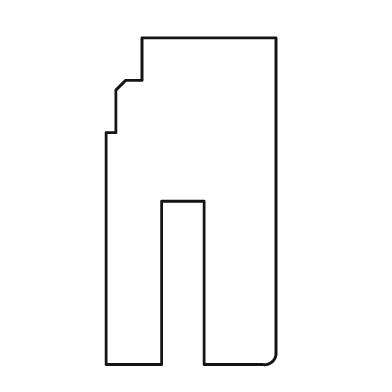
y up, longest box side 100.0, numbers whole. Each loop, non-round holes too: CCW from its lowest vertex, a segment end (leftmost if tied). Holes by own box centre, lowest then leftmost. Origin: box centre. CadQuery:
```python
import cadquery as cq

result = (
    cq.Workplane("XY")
    .moveTo(-26.0, -50.0)
    .lineTo(-9.0, -50.0)
    .lineTo(-9.0, 0.0)
    .lineTo(4.0, 0.0)
    .lineTo(4.0, -50.0)
    .lineTo(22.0, -50.0)
    .threePointArc((25.0, -49.0), (26.0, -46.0))
    .lineTo(26.0, 50.0)
    .lineTo(-15.0, 50.0)
    .lineTo(-15.0, 37.0)
    .lineTo(-20.0, 37.0)
    .lineTo(-23.0, 34.0)
    .lineTo(-23.0, 21.0)
    .lineTo(-26.0, 21.0)
    .close()
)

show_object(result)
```